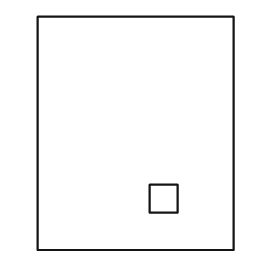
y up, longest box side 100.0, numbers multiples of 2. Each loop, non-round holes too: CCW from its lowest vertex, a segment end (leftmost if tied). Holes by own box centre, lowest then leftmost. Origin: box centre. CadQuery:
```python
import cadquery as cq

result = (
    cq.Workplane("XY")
    .moveTo(-42.0, -50.0)
    .lineTo(42.0, -50.0)
    .lineTo(42.0, 50.0)
    .lineTo(-42.0, 50.0)
    .close()
    .moveTo(6.0, -34.0)
    .lineTo(18.0, -34.0)
    .lineTo(18.0, -22.0)
    .lineTo(6.0, -22.0)
    .close()
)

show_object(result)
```